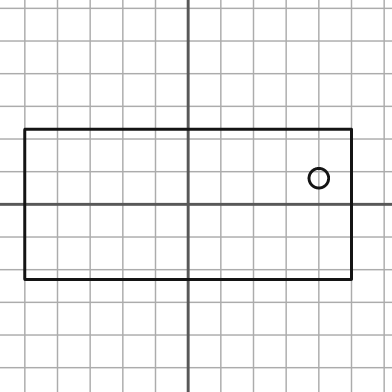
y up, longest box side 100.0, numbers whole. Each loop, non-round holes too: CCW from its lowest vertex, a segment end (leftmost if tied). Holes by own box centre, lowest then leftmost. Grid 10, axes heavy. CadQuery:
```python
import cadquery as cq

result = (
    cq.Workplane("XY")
    .moveTo(-50.0, -23.0)
    .lineTo(50.0, -23.0)
    .lineTo(50.0, 23.0)
    .lineTo(-50.0, 23.0)
    .close()
    .moveTo(40.0, 8.0)
    .circle(3.0)
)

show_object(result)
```